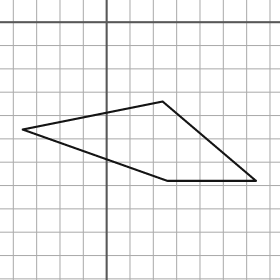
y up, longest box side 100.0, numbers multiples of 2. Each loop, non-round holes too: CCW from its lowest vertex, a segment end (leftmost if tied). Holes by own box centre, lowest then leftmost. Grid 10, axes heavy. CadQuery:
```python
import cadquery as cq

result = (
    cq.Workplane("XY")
    .moveTo(26.0, -68.0)
    .lineTo(64.0, -68.0)
    .lineTo(24.0, -34.0)
    .lineTo(-36.0, -46.0)
    .close()
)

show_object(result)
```